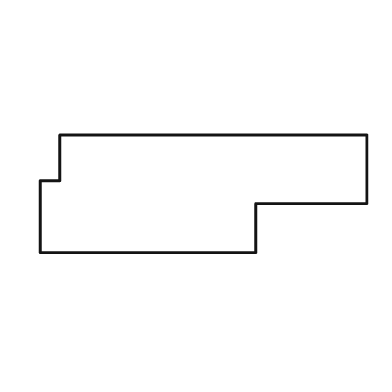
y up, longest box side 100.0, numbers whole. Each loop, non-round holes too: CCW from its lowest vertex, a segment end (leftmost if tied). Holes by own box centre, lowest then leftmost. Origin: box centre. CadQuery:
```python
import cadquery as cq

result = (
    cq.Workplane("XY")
    .moveTo(-50.0, -18.0)
    .lineTo(16.0, -18.0)
    .lineTo(16.0, -3.0)
    .lineTo(50.0, -3.0)
    .lineTo(50.0, 18.0)
    .lineTo(-44.0, 18.0)
    .lineTo(-44.0, 4.0)
    .lineTo(-50.0, 4.0)
    .close()
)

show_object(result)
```